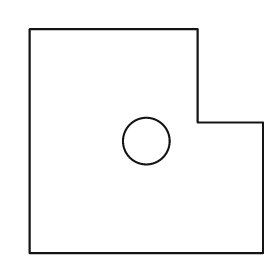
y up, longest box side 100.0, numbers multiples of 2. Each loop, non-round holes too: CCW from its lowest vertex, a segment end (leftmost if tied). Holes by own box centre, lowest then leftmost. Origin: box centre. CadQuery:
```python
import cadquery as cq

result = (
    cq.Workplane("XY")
    .moveTo(-50.0, -48.0)
    .lineTo(50.0, -48.0)
    .lineTo(50.0, 8.0)
    .lineTo(22.0, 8.0)
    .lineTo(22.0, 48.0)
    .lineTo(-50.0, 48.0)
    .close()
    .moveTo(0.0, 0.0)
    .circle(10.0)
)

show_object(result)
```